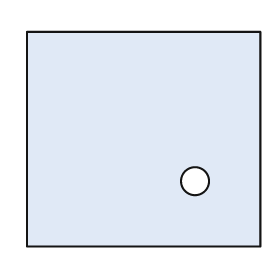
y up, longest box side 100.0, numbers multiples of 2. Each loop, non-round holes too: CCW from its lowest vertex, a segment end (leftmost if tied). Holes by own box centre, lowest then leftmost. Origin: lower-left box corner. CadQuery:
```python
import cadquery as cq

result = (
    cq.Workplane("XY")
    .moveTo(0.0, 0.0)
    .lineTo(100.0, 0.0)
    .lineTo(100.0, 92.0)
    .lineTo(0.0, 92.0)
    .close()
    .moveTo(72.0, 28.0)
    .circle(6.0)
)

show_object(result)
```